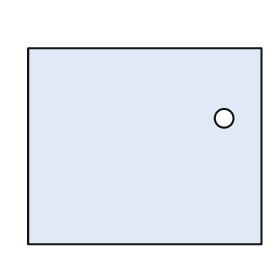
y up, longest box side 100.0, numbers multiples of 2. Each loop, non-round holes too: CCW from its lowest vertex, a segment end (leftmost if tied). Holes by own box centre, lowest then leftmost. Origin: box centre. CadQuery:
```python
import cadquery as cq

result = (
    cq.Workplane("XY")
    .moveTo(-50.0, -42.0)
    .lineTo(50.0, -42.0)
    .lineTo(50.0, 42.0)
    .lineTo(-50.0, 42.0)
    .close()
    .moveTo(34.0, 12.0)
    .circle(4.0)
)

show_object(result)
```